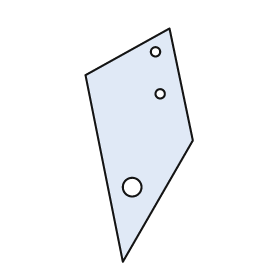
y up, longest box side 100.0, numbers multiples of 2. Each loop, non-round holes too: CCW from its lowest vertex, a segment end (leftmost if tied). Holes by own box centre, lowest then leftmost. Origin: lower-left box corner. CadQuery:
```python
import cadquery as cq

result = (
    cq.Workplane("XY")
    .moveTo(16.0, 0.0)
    .lineTo(46.0, 52.0)
    .lineTo(36.0, 100.0)
    .lineTo(0.0, 80.0)
    .close()
    .moveTo(20.0, 32.0)
    .circle(4.0)
    .moveTo(32.0, 72.0)
    .circle(2.0)
    .moveTo(30.0, 90.0)
    .circle(2.0)
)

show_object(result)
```